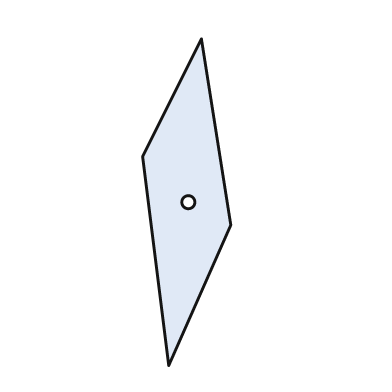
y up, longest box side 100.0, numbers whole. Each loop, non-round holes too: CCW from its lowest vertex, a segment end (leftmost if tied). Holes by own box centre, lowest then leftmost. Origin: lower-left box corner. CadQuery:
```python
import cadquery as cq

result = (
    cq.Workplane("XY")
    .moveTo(8.0, 0.0)
    .lineTo(27.0, 43.0)
    .lineTo(18.0, 100.0)
    .lineTo(0.0, 64.0)
    .close()
    .moveTo(14.0, 50.0)
    .circle(2.0)
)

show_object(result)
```